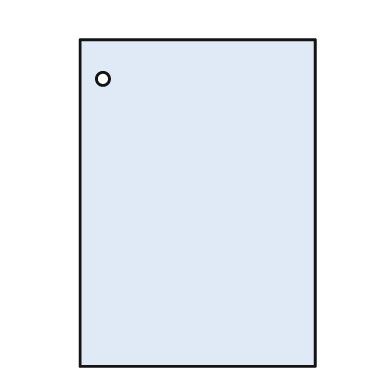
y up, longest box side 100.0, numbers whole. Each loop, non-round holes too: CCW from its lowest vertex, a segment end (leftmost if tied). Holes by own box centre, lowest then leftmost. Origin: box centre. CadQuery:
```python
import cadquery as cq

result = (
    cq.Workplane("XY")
    .moveTo(-36.0, -50.0)
    .lineTo(36.0, -50.0)
    .lineTo(36.0, 50.0)
    .lineTo(-36.0, 50.0)
    .close()
    .moveTo(-29.0, 38.0)
    .circle(2.0)
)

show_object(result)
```